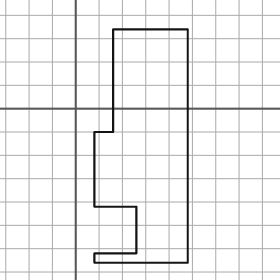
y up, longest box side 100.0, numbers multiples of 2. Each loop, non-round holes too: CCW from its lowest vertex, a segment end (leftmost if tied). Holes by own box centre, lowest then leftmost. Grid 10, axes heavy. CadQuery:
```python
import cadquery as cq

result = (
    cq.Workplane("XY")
    .moveTo(8.0, -66.0)
    .lineTo(48.0, -66.0)
    .lineTo(48.0, 34.0)
    .lineTo(16.0, 34.0)
    .lineTo(16.0, -10.0)
    .lineTo(8.0, -10.0)
    .lineTo(8.0, -42.0)
    .lineTo(26.0, -42.0)
    .lineTo(26.0, -62.0)
    .lineTo(8.0, -62.0)
    .close()
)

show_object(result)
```